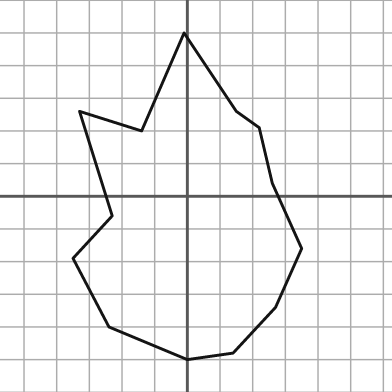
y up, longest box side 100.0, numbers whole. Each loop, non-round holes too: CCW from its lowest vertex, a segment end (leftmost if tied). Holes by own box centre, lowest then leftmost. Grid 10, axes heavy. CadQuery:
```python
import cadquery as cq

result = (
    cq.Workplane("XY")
    .moveTo(0.0, -50.0)
    .lineTo(14.0, -48.0)
    .lineTo(27.0, -34.0)
    .lineTo(35.0, -16.0)
    .lineTo(26.0, 4.0)
    .lineTo(22.0, 21.0)
    .lineTo(15.0, 26.0)
    .lineTo(-1.0, 50.0)
    .lineTo(-14.0, 20.0)
    .lineTo(-33.0, 26.0)
    .lineTo(-23.0, -6.0)
    .lineTo(-35.0, -19.0)
    .lineTo(-24.0, -40.0)
    .close()
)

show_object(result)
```